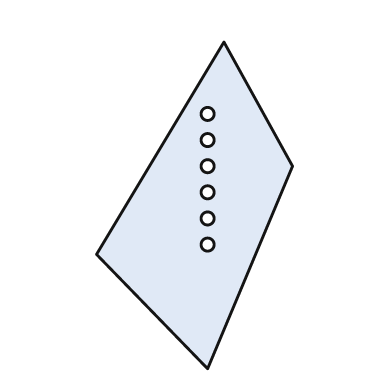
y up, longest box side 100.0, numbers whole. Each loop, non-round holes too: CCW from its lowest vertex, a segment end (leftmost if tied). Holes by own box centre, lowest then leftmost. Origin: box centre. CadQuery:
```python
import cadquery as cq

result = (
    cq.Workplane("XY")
    .moveTo(4.0, -50.0)
    .lineTo(30.0, 12.0)
    .lineTo(9.0, 50.0)
    .lineTo(-30.0, -15.0)
    .close()
    .moveTo(4.0, -12.0)
    .circle(2.0)
    .moveTo(4.0, -4.0)
    .circle(2.0)
    .moveTo(4.0, 4.0)
    .circle(2.0)
    .moveTo(4.0, 12.0)
    .circle(2.0)
    .moveTo(4.0, 20.0)
    .circle(2.0)
    .moveTo(4.0, 28.0)
    .circle(2.0)
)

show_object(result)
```